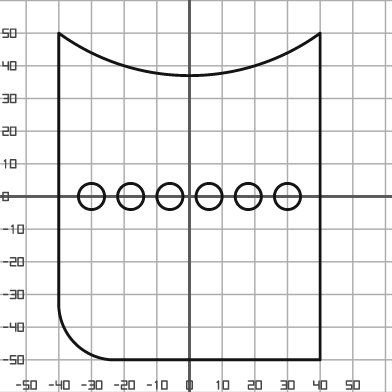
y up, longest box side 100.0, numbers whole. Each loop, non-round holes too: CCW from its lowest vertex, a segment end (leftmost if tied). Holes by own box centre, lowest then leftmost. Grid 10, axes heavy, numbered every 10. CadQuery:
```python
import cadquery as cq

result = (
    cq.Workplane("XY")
    .moveTo(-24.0, -50.0)
    .lineTo(40.0, -50.0)
    .lineTo(40.0, 50.0)
    .threePointArc((0.0, 37.0), (-40.0, 50.0))
    .lineTo(-40.0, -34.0)
    .threePointArc((-35.0, -45.0), (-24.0, -50.0))
    .close()
    .moveTo(-30.0, 0.0)
    .circle(4.0)
    .moveTo(-18.0, 0.0)
    .circle(4.0)
    .moveTo(-6.0, 0.0)
    .circle(4.0)
    .moveTo(6.0, 0.0)
    .circle(4.0)
    .moveTo(18.0, 0.0)
    .circle(4.0)
    .moveTo(30.0, 0.0)
    .circle(4.0)
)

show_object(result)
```